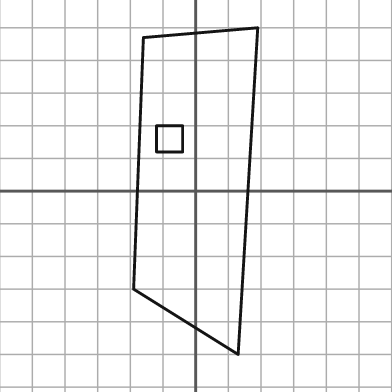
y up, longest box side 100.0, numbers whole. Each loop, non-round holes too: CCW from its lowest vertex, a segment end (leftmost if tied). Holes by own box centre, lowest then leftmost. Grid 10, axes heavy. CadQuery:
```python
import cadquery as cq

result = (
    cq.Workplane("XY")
    .moveTo(13.0, -50.0)
    .lineTo(19.0, 50.0)
    .lineTo(-16.0, 47.0)
    .lineTo(-19.0, -30.0)
    .close()
    .moveTo(-12.0, 12.0)
    .lineTo(-4.0, 12.0)
    .lineTo(-4.0, 20.0)
    .lineTo(-12.0, 20.0)
    .close()
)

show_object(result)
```